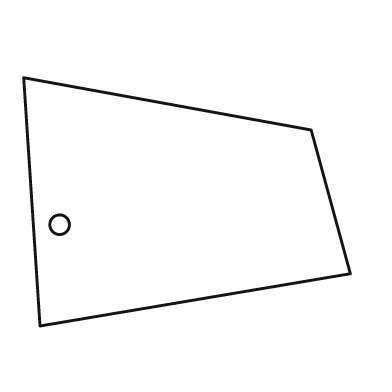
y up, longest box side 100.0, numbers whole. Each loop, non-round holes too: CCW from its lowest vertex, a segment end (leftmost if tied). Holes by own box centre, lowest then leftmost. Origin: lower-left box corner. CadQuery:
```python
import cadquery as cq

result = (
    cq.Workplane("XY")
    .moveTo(5.0, 0.0)
    .lineTo(100.0, 16.0)
    .lineTo(88.0, 60.0)
    .lineTo(0.0, 76.0)
    .close()
    .moveTo(11.0, 31.0)
    .circle(3.0)
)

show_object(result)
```